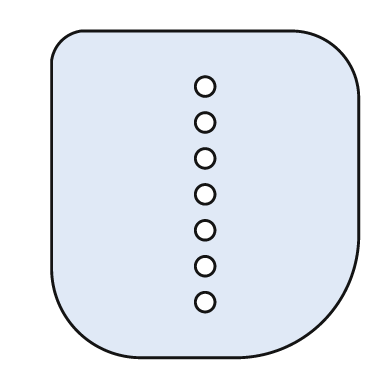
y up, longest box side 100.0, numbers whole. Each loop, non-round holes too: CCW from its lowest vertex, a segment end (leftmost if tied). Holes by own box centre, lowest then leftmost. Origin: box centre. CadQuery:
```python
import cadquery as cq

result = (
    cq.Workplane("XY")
    .moveTo(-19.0, -50.0)
    .lineTo(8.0, -50.0)
    .threePointArc((36.0, -39.0), (47.0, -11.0))
    .lineTo(47.0, 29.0)
    .threePointArc((41.0, 44.0), (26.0, 50.0))
    .lineTo(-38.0, 50.0)
    .threePointArc((-44.0, 47.0), (-47.0, 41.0))
    .lineTo(-47.0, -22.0)
    .threePointArc((-39.0, -42.0), (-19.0, -50.0))
    .close()
    .moveTo(0.0, -33.0)
    .circle(3.0)
    .moveTo(0.0, -22.0)
    .circle(3.0)
    .moveTo(0.0, -11.0)
    .circle(3.0)
    .moveTo(0.0, 0.0)
    .circle(3.0)
    .moveTo(0.0, 11.0)
    .circle(3.0)
    .moveTo(0.0, 22.0)
    .circle(3.0)
    .moveTo(0.0, 33.0)
    .circle(3.0)
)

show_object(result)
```